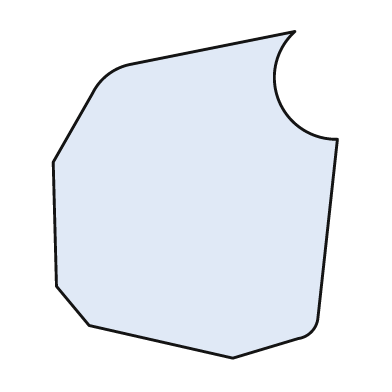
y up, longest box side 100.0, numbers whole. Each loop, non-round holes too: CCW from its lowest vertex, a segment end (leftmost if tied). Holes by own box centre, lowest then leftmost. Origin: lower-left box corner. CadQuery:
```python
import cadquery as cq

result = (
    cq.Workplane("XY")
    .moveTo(55.0, 0.0)
    .lineTo(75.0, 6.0)
    .threePointArc((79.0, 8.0), (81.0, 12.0))
    .lineTo(87.0, 67.0)
    .threePointArc((69.0, 79.0), (74.0, 100.0))
    .lineTo(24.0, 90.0)
    .threePointArc((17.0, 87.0), (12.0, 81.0))
    .lineTo(0.0, 60.0)
    .lineTo(1.0, 22.0)
    .lineTo(11.0, 10.0)
    .close()
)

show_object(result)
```